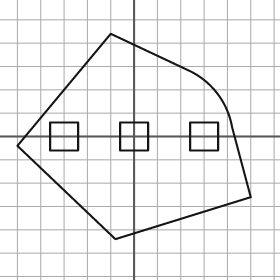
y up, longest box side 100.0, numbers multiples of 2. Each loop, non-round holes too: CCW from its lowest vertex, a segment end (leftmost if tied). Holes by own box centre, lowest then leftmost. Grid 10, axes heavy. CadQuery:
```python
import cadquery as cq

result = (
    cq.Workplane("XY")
    .moveTo(-8.0, -44.0)
    .lineTo(50.0, -26.0)
    .lineTo(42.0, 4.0)
    .threePointArc((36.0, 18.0), (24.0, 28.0))
    .lineTo(-10.0, 44.0)
    .lineTo(-50.0, -4.0)
    .close()
    .moveTo(-36.0, -6.0)
    .lineTo(-24.0, -6.0)
    .lineTo(-24.0, 6.0)
    .lineTo(-36.0, 6.0)
    .close()
    .moveTo(-6.0, -6.0)
    .lineTo(6.0, -6.0)
    .lineTo(6.0, 6.0)
    .lineTo(-6.0, 6.0)
    .close()
    .moveTo(24.0, -6.0)
    .lineTo(36.0, -6.0)
    .lineTo(36.0, 6.0)
    .lineTo(24.0, 6.0)
    .close()
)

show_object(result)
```